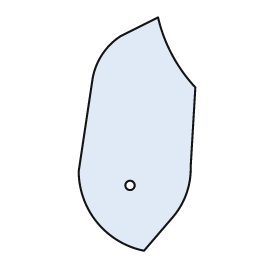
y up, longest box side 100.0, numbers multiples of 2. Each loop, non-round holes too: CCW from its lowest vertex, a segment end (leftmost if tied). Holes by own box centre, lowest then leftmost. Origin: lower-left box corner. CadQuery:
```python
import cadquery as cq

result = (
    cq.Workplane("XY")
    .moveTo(28.0, 0.0)
    .lineTo(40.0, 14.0)
    .threePointArc((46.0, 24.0), (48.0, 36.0))
    .lineTo(50.0, 70.0)
    .threePointArc((40.0, 84.0), (34.0, 100.0))
    .lineTo(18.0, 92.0)
    .threePointArc((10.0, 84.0), (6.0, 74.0))
    .lineTo(0.0, 34.0)
    .threePointArc((8.0, 12.0), (28.0, 0.0))
    .close()
    .moveTo(22.0, 28.0)
    .circle(2.0)
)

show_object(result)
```